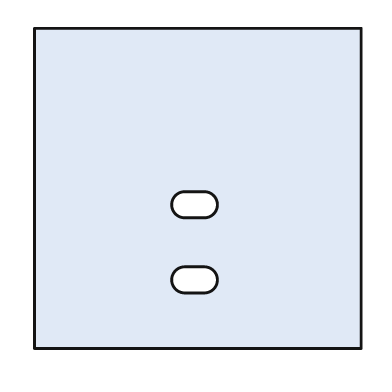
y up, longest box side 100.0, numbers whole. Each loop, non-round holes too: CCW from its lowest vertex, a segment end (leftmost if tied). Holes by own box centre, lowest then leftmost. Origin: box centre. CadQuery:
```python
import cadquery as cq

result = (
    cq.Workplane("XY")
    .moveTo(-50.0, -49.0)
    .lineTo(50.0, -49.0)
    .lineTo(50.0, 49.0)
    .lineTo(-50.0, 49.0)
    .close()
    .moveTo(-4.0, -32.0)
    .lineTo(2.0, -32.0)
    .threePointArc((6.0, -28.0), (2.0, -24.0))
    .lineTo(-4.0, -24.0)
    .threePointArc((-8.0, -28.0), (-4.0, -32.0))
    .close()
    .moveTo(-4.0, -9.0)
    .lineTo(2.0, -9.0)
    .threePointArc((6.0, -5.0), (2.0, -1.0))
    .lineTo(-4.0, -1.0)
    .threePointArc((-8.0, -5.0), (-4.0, -9.0))
    .close()
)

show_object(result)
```